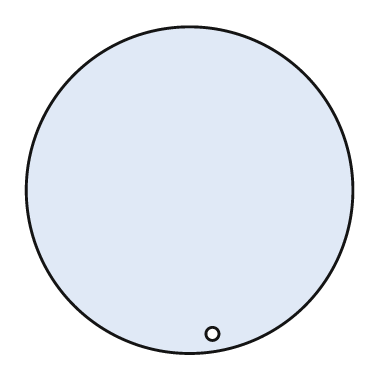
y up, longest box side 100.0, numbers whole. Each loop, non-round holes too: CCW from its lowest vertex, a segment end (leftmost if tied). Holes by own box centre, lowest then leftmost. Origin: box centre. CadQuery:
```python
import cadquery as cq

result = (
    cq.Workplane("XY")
    .moveTo(0.0, 0.0)
    .circle(50.0)
    .moveTo(7.0, -44.0)
    .circle(2.0)
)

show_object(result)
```